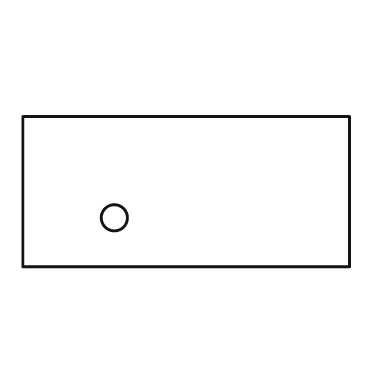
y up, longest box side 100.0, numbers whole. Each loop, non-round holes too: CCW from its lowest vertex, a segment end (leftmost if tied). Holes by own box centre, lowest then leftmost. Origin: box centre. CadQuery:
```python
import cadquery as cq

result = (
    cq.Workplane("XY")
    .moveTo(-50.0, -23.0)
    .lineTo(50.0, -23.0)
    .lineTo(50.0, 23.0)
    .lineTo(-50.0, 23.0)
    .close()
    .moveTo(-22.0, -8.0)
    .circle(4.0)
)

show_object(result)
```